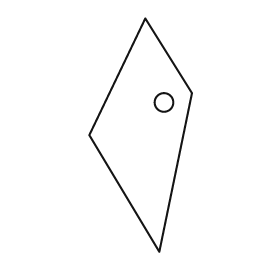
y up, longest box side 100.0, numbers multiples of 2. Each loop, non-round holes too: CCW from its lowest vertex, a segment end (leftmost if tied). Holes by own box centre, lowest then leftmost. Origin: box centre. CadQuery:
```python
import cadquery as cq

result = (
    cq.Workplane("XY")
    .moveTo(8.0, -50.0)
    .lineTo(22.0, 18.0)
    .lineTo(2.0, 50.0)
    .lineTo(-22.0, 0.0)
    .close()
    .moveTo(10.0, 14.0)
    .circle(4.0)
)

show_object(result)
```